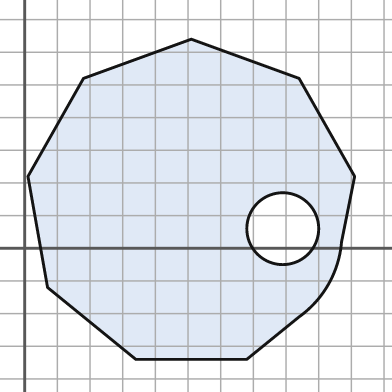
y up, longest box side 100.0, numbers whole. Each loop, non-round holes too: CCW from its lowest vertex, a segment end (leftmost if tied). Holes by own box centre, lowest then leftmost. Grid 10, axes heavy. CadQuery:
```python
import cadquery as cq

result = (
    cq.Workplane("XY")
    .moveTo(34.0, -34.0)
    .lineTo(68.0, -34.0)
    .lineTo(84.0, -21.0)
    .threePointArc((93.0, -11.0), (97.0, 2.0))
    .lineTo(101.0, 22.0)
    .lineTo(84.0, 52.0)
    .lineTo(51.0, 64.0)
    .lineTo(18.0, 52.0)
    .lineTo(1.0, 22.0)
    .lineTo(7.0, -12.0)
    .close()
    .moveTo(79.0, 6.0)
    .circle(11.0)
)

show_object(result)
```